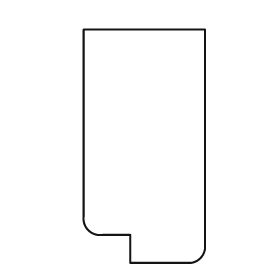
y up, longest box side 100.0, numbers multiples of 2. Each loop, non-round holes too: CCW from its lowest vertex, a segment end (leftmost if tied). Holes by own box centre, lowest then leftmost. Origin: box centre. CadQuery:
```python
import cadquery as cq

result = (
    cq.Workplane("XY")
    .moveTo(-6.0, -50.0)
    .lineTo(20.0, -50.0)
    .threePointArc((24.0, -48.0), (26.0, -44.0))
    .lineTo(26.0, 50.0)
    .lineTo(-26.0, 50.0)
    .lineTo(-26.0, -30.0)
    .threePointArc((-24.0, -36.0), (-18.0, -38.0))
    .lineTo(-6.0, -38.0)
    .close()
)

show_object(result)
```